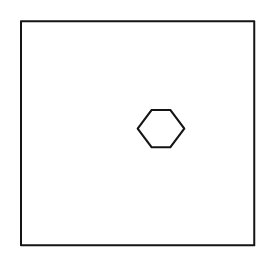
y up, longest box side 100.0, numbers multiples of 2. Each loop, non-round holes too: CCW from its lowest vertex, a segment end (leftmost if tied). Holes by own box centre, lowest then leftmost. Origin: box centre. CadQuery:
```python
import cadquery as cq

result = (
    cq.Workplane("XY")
    .moveTo(-50.0, -48.0)
    .lineTo(50.0, -48.0)
    .lineTo(50.0, 48.0)
    .lineTo(-50.0, 48.0)
    .close()
    .moveTo(6.0, -6.0)
    .lineTo(14.0, -6.0)
    .lineTo(20.0, 2.0)
    .lineTo(14.0, 10.0)
    .lineTo(6.0, 10.0)
    .lineTo(0.0, 2.0)
    .close()
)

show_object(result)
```